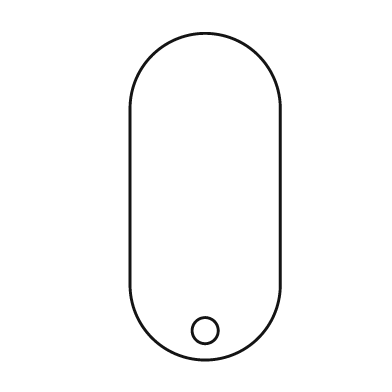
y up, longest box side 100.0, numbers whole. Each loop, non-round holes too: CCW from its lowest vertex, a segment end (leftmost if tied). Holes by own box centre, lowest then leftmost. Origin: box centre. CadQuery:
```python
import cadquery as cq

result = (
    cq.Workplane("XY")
    .moveTo(-23.0, -27.0)
    .threePointArc((0.0, -50.0), (23.0, -27.0))
    .lineTo(23.0, 27.0)
    .threePointArc((0.0, 50.0), (-23.0, 27.0))
    .close()
    .moveTo(0.0, -41.0)
    .circle(4.0)
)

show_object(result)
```